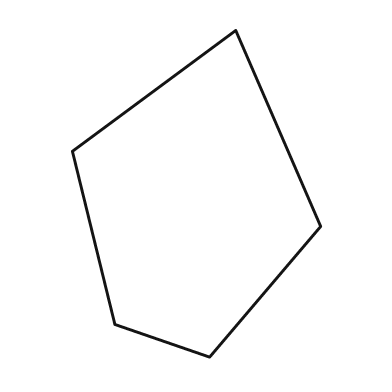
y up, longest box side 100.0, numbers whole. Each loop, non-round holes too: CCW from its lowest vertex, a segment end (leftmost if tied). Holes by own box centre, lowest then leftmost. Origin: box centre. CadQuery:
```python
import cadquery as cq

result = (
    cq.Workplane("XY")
    .moveTo(4.0, -50.0)
    .lineTo(38.0, -10.0)
    .lineTo(12.0, 50.0)
    .lineTo(-38.0, 13.0)
    .lineTo(-25.0, -40.0)
    .close()
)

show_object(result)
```